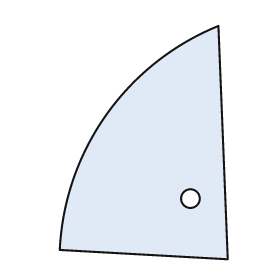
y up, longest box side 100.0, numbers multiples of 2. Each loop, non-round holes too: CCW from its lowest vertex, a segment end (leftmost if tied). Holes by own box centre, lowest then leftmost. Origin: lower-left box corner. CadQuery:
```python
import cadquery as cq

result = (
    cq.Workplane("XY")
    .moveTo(72.0, 0.0)
    .lineTo(68.0, 100.0)
    .threePointArc((20.0, 62.0), (0.0, 4.0))
    .close()
    .moveTo(56.0, 26.0)
    .circle(4.0)
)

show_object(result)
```